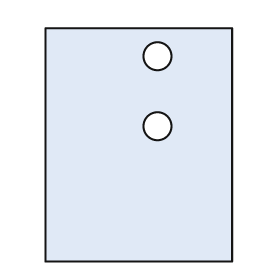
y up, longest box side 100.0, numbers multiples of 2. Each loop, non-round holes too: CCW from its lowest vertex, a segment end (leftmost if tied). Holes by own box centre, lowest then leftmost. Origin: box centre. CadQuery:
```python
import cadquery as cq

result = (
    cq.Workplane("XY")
    .moveTo(-40.0, -50.0)
    .lineTo(40.0, -50.0)
    .lineTo(40.0, 50.0)
    .lineTo(-40.0, 50.0)
    .close()
    .moveTo(8.0, 8.0)
    .circle(6.0)
    .moveTo(8.0, 38.0)
    .circle(6.0)
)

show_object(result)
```